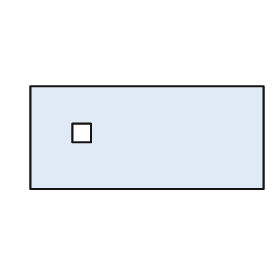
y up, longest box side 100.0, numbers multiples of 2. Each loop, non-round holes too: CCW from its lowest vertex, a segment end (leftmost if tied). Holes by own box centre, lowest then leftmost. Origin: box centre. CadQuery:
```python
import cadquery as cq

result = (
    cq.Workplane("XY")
    .moveTo(-50.0, -22.0)
    .lineTo(50.0, -22.0)
    .lineTo(50.0, 22.0)
    .lineTo(-50.0, 22.0)
    .close()
    .moveTo(-32.0, -2.0)
    .lineTo(-24.0, -2.0)
    .lineTo(-24.0, 6.0)
    .lineTo(-32.0, 6.0)
    .close()
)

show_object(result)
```